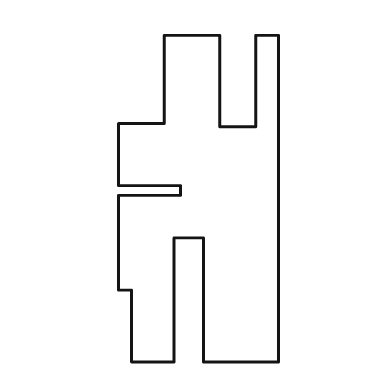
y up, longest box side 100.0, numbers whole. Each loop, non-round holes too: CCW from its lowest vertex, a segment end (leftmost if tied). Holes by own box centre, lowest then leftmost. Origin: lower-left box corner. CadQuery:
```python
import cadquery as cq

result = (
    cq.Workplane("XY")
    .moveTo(4.0, 0.0)
    .lineTo(17.0, 0.0)
    .lineTo(17.0, 38.0)
    .lineTo(26.0, 38.0)
    .lineTo(26.0, 0.0)
    .lineTo(49.0, 0.0)
    .lineTo(49.0, 100.0)
    .lineTo(42.0, 100.0)
    .lineTo(42.0, 72.0)
    .lineTo(31.0, 72.0)
    .lineTo(31.0, 100.0)
    .lineTo(14.0, 100.0)
    .lineTo(14.0, 73.0)
    .lineTo(0.0, 73.0)
    .lineTo(0.0, 54.0)
    .lineTo(19.0, 54.0)
    .lineTo(19.0, 51.0)
    .lineTo(0.0, 51.0)
    .lineTo(0.0, 22.0)
    .lineTo(4.0, 22.0)
    .close()
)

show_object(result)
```